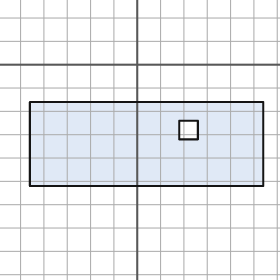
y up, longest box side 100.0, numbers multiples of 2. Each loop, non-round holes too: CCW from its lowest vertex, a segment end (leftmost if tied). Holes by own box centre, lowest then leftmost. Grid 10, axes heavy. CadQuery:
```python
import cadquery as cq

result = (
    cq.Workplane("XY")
    .moveTo(-46.0, -52.0)
    .lineTo(54.0, -52.0)
    .lineTo(54.0, -16.0)
    .lineTo(-46.0, -16.0)
    .close()
    .moveTo(18.0, -32.0)
    .lineTo(26.0, -32.0)
    .lineTo(26.0, -24.0)
    .lineTo(18.0, -24.0)
    .close()
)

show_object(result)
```